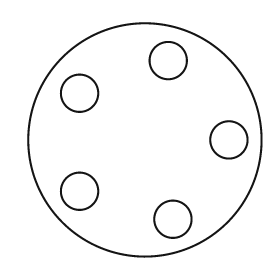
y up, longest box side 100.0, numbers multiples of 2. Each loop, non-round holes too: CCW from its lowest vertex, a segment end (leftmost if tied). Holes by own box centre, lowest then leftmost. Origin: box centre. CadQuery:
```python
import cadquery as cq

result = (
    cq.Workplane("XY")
    .moveTo(0.0, 0.0)
    .circle(50.0)
    .moveTo(12.0, -34.0)
    .circle(8.0)
    .moveTo(-28.0, -22.0)
    .circle(8.0)
    .moveTo(36.0, 0.0)
    .circle(8.0)
    .moveTo(-28.0, 20.0)
    .circle(8.0)
    .moveTo(10.0, 34.0)
    .circle(8.0)
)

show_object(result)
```